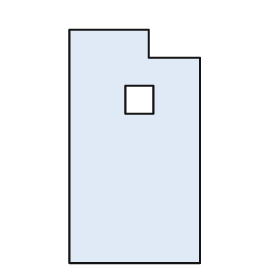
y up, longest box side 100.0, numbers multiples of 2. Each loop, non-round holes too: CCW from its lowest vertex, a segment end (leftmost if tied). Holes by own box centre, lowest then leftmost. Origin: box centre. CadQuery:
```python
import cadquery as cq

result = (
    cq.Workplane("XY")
    .moveTo(-28.0, -50.0)
    .lineTo(28.0, -50.0)
    .lineTo(28.0, 38.0)
    .lineTo(6.0, 38.0)
    .lineTo(6.0, 50.0)
    .lineTo(-28.0, 50.0)
    .close()
    .moveTo(-4.0, 14.0)
    .lineTo(8.0, 14.0)
    .lineTo(8.0, 26.0)
    .lineTo(-4.0, 26.0)
    .close()
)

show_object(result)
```